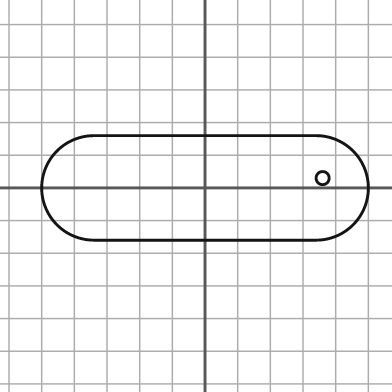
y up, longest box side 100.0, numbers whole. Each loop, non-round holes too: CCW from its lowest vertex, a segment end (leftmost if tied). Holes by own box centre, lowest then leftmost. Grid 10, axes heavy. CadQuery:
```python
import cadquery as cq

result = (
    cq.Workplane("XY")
    .moveTo(-34.0, -16.0)
    .lineTo(34.0, -16.0)
    .threePointArc((50.0, 0.0), (34.0, 16.0))
    .lineTo(-34.0, 16.0)
    .threePointArc((-50.0, 0.0), (-34.0, -16.0))
    .close()
    .moveTo(36.0, 3.0)
    .circle(2.0)
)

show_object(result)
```